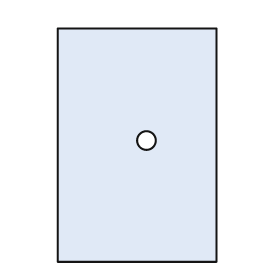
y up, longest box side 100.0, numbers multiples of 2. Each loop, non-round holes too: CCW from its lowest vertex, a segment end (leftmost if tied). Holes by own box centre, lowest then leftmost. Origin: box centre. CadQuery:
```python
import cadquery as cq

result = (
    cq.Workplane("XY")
    .moveTo(-34.0, -50.0)
    .lineTo(34.0, -50.0)
    .lineTo(34.0, 50.0)
    .lineTo(-34.0, 50.0)
    .close()
    .moveTo(4.0, 2.0)
    .circle(4.0)
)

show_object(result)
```